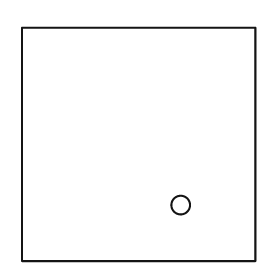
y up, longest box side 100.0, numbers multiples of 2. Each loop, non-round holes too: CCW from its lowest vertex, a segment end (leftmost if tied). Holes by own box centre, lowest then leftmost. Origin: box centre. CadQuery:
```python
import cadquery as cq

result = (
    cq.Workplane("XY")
    .moveTo(-50.0, -50.0)
    .lineTo(50.0, -50.0)
    .lineTo(50.0, 50.0)
    .lineTo(-50.0, 50.0)
    .close()
    .moveTo(18.0, -26.0)
    .circle(4.0)
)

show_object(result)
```